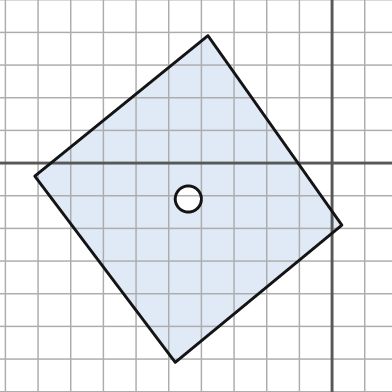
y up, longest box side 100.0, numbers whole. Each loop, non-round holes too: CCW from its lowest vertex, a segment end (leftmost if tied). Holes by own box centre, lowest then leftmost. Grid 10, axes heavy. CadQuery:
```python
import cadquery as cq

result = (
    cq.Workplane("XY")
    .moveTo(-48.0, -61.0)
    .lineTo(3.0, -19.0)
    .lineTo(-38.0, 39.0)
    .lineTo(-91.0, -4.0)
    .close()
    .moveTo(-44.0, -11.0)
    .circle(4.0)
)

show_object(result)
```